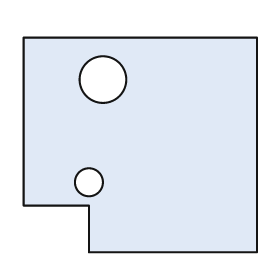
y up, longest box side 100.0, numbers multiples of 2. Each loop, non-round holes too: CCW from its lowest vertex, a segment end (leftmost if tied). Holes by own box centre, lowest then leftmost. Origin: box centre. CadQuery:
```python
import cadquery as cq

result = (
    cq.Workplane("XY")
    .moveTo(-22.0, -46.0)
    .lineTo(50.0, -46.0)
    .lineTo(50.0, 46.0)
    .lineTo(-50.0, 46.0)
    .lineTo(-50.0, -26.0)
    .lineTo(-22.0, -26.0)
    .close()
    .moveTo(-22.0, -16.0)
    .circle(6.0)
    .moveTo(-16.0, 28.0)
    .circle(10.0)
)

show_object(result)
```